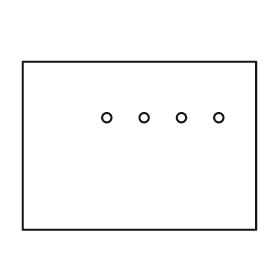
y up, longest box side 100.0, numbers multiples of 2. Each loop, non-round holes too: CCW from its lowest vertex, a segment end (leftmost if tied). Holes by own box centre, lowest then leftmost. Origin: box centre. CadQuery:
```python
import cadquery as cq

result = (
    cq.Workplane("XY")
    .moveTo(-50.0, -36.0)
    .lineTo(50.0, -36.0)
    .lineTo(50.0, 36.0)
    .lineTo(-50.0, 36.0)
    .close()
    .moveTo(-14.0, 12.0)
    .circle(2.0)
    .moveTo(2.0, 12.0)
    .circle(2.0)
    .moveTo(18.0, 12.0)
    .circle(2.0)
    .moveTo(34.0, 12.0)
    .circle(2.0)
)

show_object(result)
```